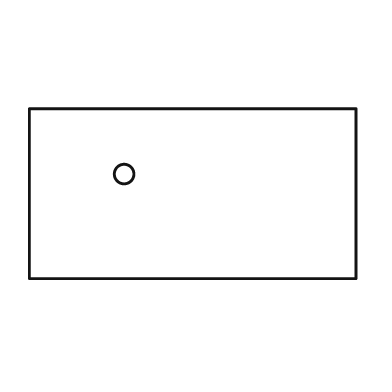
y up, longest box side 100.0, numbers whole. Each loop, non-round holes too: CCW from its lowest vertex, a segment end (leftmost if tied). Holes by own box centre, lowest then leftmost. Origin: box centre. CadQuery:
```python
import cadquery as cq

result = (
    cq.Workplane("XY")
    .moveTo(-50.0, -26.0)
    .lineTo(50.0, -26.0)
    .lineTo(50.0, 26.0)
    .lineTo(-50.0, 26.0)
    .close()
    .moveTo(-21.0, 6.0)
    .circle(3.0)
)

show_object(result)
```